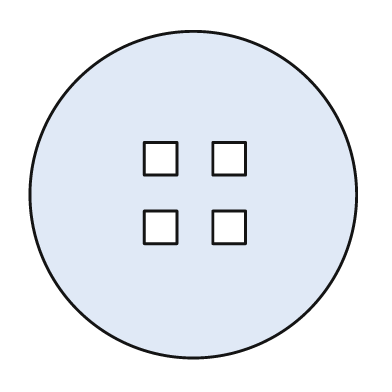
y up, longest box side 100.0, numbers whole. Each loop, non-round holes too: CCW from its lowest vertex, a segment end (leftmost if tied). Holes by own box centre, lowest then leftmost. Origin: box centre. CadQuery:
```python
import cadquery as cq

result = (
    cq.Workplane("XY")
    .moveTo(0.0, 0.0)
    .circle(50.0)
    .moveTo(-15.0, -15.0)
    .lineTo(-5.0, -15.0)
    .lineTo(-5.0, -5.0)
    .lineTo(-15.0, -5.0)
    .close()
    .moveTo(6.0, -15.0)
    .lineTo(16.0, -15.0)
    .lineTo(16.0, -5.0)
    .lineTo(6.0, -5.0)
    .close()
    .moveTo(-15.0, 6.0)
    .lineTo(-5.0, 6.0)
    .lineTo(-5.0, 16.0)
    .lineTo(-15.0, 16.0)
    .close()
    .moveTo(6.0, 6.0)
    .lineTo(16.0, 6.0)
    .lineTo(16.0, 16.0)
    .lineTo(6.0, 16.0)
    .close()
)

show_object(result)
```